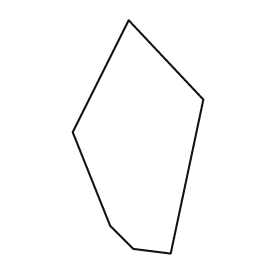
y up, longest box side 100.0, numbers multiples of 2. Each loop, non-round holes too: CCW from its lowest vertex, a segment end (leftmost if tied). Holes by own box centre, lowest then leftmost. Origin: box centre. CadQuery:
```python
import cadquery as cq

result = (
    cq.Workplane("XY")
    .moveTo(14.0, -50.0)
    .lineTo(28.0, 16.0)
    .lineTo(-4.0, 50.0)
    .lineTo(-28.0, 2.0)
    .lineTo(-12.0, -38.0)
    .lineTo(-2.0, -48.0)
    .close()
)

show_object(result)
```